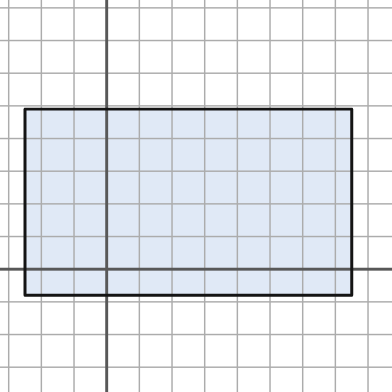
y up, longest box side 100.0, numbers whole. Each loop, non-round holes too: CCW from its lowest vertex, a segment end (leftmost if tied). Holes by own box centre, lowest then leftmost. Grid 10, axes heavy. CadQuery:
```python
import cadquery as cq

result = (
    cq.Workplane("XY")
    .moveTo(-25.0, -8.0)
    .lineTo(75.0, -8.0)
    .lineTo(75.0, 49.0)
    .lineTo(-25.0, 49.0)
    .close()
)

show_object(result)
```